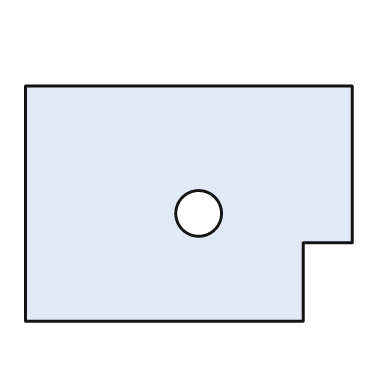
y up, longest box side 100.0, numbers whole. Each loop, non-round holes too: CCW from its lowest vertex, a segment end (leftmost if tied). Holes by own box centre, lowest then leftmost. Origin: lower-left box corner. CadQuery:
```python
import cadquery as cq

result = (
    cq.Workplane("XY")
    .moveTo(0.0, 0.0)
    .lineTo(85.0, 0.0)
    .lineTo(85.0, 24.0)
    .lineTo(100.0, 24.0)
    .lineTo(100.0, 72.0)
    .lineTo(0.0, 72.0)
    .close()
    .moveTo(53.0, 33.0)
    .circle(7.0)
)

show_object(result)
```